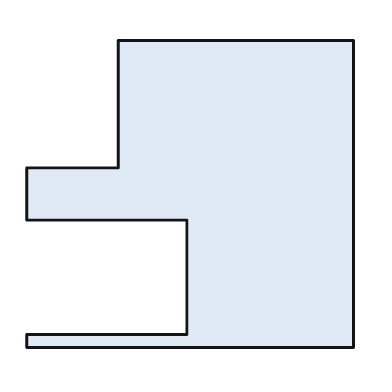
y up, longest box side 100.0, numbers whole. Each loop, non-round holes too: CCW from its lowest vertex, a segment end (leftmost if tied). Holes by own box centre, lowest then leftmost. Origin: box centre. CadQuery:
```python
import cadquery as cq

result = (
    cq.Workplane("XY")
    .moveTo(-50.0, -47.0)
    .lineTo(50.0, -47.0)
    .lineTo(50.0, 47.0)
    .lineTo(-22.0, 47.0)
    .lineTo(-22.0, 8.0)
    .lineTo(-50.0, 8.0)
    .lineTo(-50.0, -8.0)
    .lineTo(-1.0, -8.0)
    .lineTo(-1.0, -43.0)
    .lineTo(-50.0, -43.0)
    .close()
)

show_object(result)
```